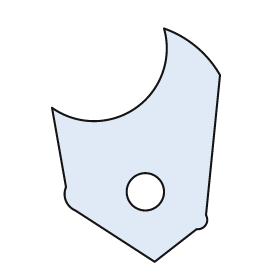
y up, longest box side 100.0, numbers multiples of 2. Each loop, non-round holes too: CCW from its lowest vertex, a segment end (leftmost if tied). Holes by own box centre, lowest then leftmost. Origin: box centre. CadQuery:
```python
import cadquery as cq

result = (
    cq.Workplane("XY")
    .moveTo(8.0, -50.0)
    .lineTo(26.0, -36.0)
    .threePointArc((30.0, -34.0), (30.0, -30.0))
    .lineTo(36.0, 30.0)
    .threePointArc((26.0, 42.0), (12.0, 50.0))
    .threePointArc((0.0, 16.0), (-36.0, 16.0))
    .lineTo(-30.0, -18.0)
    .threePointArc((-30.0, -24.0), (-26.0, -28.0))
    .close()
    .moveTo(4.0, -20.0)
    .circle(8.0)
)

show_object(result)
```